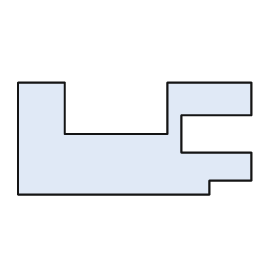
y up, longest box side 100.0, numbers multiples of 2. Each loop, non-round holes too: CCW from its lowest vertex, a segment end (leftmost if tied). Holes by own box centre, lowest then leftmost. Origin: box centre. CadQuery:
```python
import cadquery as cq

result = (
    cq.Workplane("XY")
    .moveTo(-50.0, -24.0)
    .lineTo(32.0, -24.0)
    .lineTo(32.0, -18.0)
    .lineTo(50.0, -18.0)
    .lineTo(50.0, -6.0)
    .lineTo(20.0, -6.0)
    .lineTo(20.0, 10.0)
    .lineTo(50.0, 10.0)
    .lineTo(50.0, 24.0)
    .lineTo(14.0, 24.0)
    .lineTo(14.0, 2.0)
    .lineTo(-30.0, 2.0)
    .lineTo(-30.0, 24.0)
    .lineTo(-50.0, 24.0)
    .close()
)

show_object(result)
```